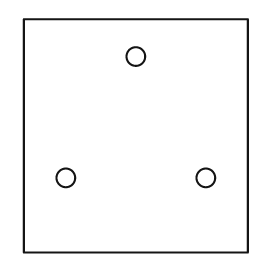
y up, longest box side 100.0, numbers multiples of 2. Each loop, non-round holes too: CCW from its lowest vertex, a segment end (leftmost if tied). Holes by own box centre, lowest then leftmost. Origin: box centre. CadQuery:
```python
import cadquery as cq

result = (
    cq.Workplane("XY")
    .moveTo(-48.0, -50.0)
    .lineTo(48.0, -50.0)
    .lineTo(48.0, 50.0)
    .lineTo(-48.0, 50.0)
    .close()
    .moveTo(-30.0, -18.0)
    .circle(4.0)
    .moveTo(30.0, -18.0)
    .circle(4.0)
    .moveTo(0.0, 34.0)
    .circle(4.0)
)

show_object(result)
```